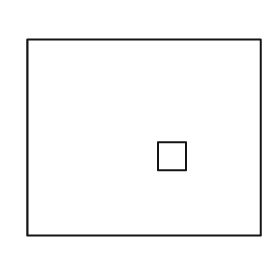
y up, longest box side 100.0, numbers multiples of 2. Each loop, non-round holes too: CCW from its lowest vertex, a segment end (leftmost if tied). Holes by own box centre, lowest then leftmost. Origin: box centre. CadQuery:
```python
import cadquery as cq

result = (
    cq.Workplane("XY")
    .moveTo(-50.0, -42.0)
    .lineTo(50.0, -42.0)
    .lineTo(50.0, 42.0)
    .lineTo(-50.0, 42.0)
    .close()
    .moveTo(6.0, -14.0)
    .lineTo(18.0, -14.0)
    .lineTo(18.0, -2.0)
    .lineTo(6.0, -2.0)
    .close()
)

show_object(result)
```